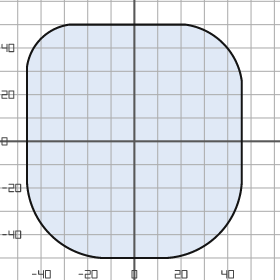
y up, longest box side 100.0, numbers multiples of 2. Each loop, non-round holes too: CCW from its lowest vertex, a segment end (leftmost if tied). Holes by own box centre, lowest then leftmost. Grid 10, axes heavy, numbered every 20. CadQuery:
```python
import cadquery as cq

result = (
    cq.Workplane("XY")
    .moveTo(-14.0, -50.0)
    .lineTo(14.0, -50.0)
    .threePointArc((36.0, -40.0), (46.0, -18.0))
    .lineTo(46.0, 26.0)
    .threePointArc((38.0, 42.0), (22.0, 50.0))
    .lineTo(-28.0, 50.0)
    .threePointArc((-40.0, 44.0), (-46.0, 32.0))
    .lineTo(-46.0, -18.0)
    .threePointArc((-36.0, -40.0), (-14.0, -50.0))
    .close()
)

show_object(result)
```